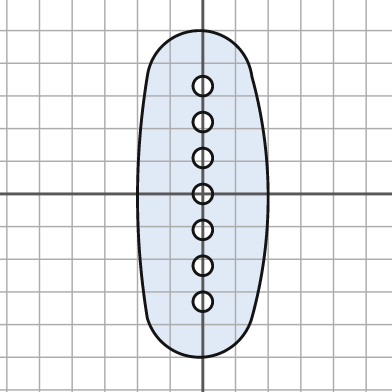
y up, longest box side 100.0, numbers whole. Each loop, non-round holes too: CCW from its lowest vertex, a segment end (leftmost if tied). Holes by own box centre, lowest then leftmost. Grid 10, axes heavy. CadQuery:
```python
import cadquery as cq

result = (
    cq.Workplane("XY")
    .moveTo(-17.0, -38.0)
    .threePointArc((-1.0, -50.0), (15.0, -38.0))
    .threePointArc((20.0, -1.0), (15.0, 36.0))
    .threePointArc((-1.0, 50.0), (-17.0, 36.0))
    .threePointArc((-20.0, -1.0), (-17.0, -38.0))
    .close()
    .moveTo(0.0, -33.0)
    .circle(3.0)
    .moveTo(0.0, -22.0)
    .circle(3.0)
    .moveTo(0.0, -11.0)
    .circle(3.0)
    .moveTo(0.0, 0.0)
    .circle(3.0)
    .moveTo(0.0, 11.0)
    .circle(3.0)
    .moveTo(0.0, 22.0)
    .circle(3.0)
    .moveTo(0.0, 33.0)
    .circle(3.0)
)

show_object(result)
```